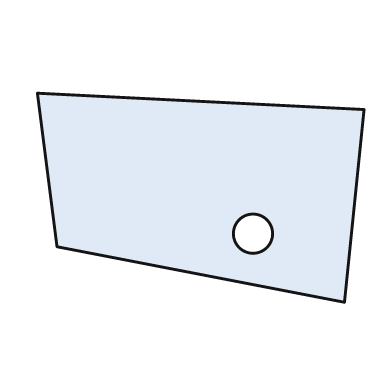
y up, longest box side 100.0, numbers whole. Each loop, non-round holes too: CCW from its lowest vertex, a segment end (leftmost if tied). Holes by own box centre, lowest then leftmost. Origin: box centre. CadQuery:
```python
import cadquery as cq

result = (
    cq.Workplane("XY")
    .moveTo(44.0, -32.0)
    .lineTo(50.0, 27.0)
    .lineTo(-50.0, 32.0)
    .lineTo(-44.0, -15.0)
    .close()
    .moveTo(16.0, -11.0)
    .circle(6.0)
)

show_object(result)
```